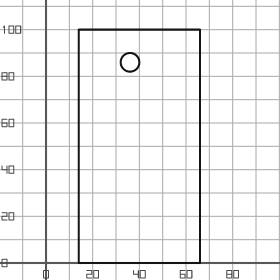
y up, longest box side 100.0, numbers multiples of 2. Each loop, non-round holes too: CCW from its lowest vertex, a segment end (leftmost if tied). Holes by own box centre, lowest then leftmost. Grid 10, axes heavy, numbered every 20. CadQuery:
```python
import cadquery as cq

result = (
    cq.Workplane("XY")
    .moveTo(14.0, 0.0)
    .lineTo(66.0, 0.0)
    .lineTo(66.0, 100.0)
    .lineTo(14.0, 100.0)
    .close()
    .moveTo(36.0, 86.0)
    .circle(4.0)
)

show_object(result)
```